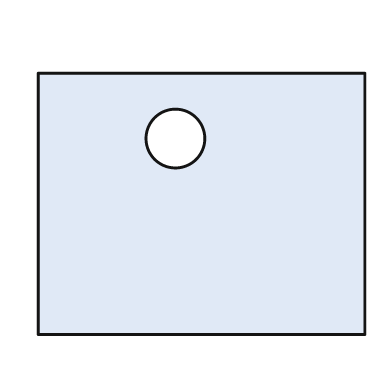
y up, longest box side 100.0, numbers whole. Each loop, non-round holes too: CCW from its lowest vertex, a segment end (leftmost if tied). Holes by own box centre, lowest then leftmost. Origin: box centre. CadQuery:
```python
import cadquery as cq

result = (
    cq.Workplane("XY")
    .moveTo(-50.0, -40.0)
    .lineTo(50.0, -40.0)
    .lineTo(50.0, 40.0)
    .lineTo(-50.0, 40.0)
    .close()
    .moveTo(-8.0, 20.0)
    .circle(9.0)
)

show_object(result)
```